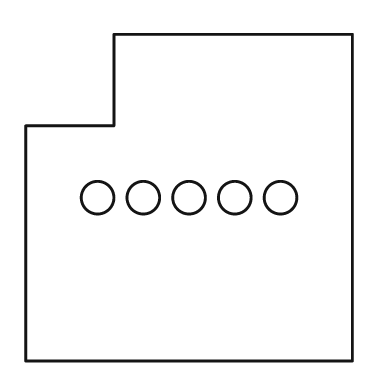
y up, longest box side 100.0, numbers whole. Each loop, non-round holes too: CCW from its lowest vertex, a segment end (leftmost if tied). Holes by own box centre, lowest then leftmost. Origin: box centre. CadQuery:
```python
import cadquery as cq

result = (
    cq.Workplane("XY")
    .moveTo(-50.0, -50.0)
    .lineTo(50.0, -50.0)
    .lineTo(50.0, 50.0)
    .lineTo(-23.0, 50.0)
    .lineTo(-23.0, 22.0)
    .lineTo(-50.0, 22.0)
    .close()
    .moveTo(-28.0, 0.0)
    .circle(5.0)
    .moveTo(-14.0, 0.0)
    .circle(5.0)
    .moveTo(0.0, 0.0)
    .circle(5.0)
    .moveTo(14.0, 0.0)
    .circle(5.0)
    .moveTo(28.0, 0.0)
    .circle(5.0)
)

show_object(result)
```